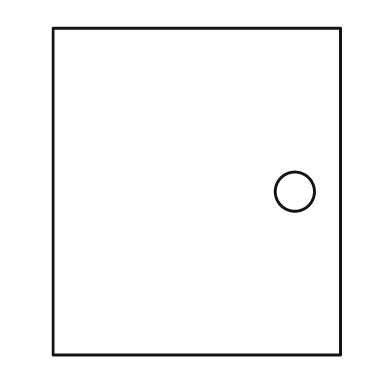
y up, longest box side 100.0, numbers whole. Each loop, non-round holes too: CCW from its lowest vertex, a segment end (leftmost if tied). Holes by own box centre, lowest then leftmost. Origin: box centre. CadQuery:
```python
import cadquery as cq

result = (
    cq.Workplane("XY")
    .moveTo(-44.0, -50.0)
    .lineTo(44.0, -50.0)
    .lineTo(44.0, 50.0)
    .lineTo(-44.0, 50.0)
    .close()
    .moveTo(30.0, 0.0)
    .circle(6.0)
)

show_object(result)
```